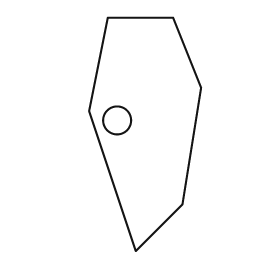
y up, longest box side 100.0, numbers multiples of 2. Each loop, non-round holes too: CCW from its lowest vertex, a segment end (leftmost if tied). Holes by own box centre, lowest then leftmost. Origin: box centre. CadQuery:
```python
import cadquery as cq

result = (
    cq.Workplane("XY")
    .moveTo(-4.0, -50.0)
    .lineTo(16.0, -30.0)
    .lineTo(24.0, 20.0)
    .lineTo(12.0, 50.0)
    .lineTo(-16.0, 50.0)
    .lineTo(-24.0, 10.0)
    .close()
    .moveTo(-12.0, 6.0)
    .circle(6.0)
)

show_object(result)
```